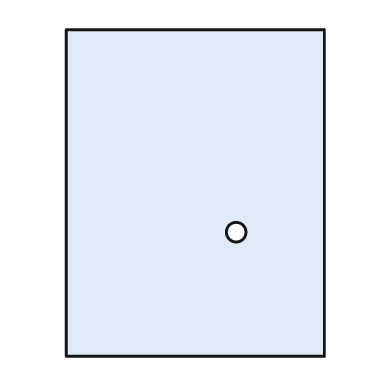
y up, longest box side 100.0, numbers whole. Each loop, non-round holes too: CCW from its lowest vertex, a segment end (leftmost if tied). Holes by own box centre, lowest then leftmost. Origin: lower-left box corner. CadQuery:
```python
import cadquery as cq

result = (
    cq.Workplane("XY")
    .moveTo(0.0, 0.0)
    .lineTo(79.0, 0.0)
    .lineTo(79.0, 100.0)
    .lineTo(0.0, 100.0)
    .close()
    .moveTo(52.0, 38.0)
    .circle(3.0)
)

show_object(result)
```